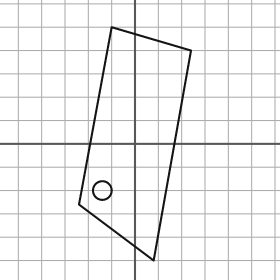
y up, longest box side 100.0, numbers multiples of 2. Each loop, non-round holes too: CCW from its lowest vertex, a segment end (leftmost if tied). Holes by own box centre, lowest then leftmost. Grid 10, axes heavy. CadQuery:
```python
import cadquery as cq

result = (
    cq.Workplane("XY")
    .moveTo(8.0, -50.0)
    .lineTo(24.0, 40.0)
    .lineTo(-10.0, 50.0)
    .lineTo(-24.0, -26.0)
    .close()
    .moveTo(-14.0, -20.0)
    .circle(4.0)
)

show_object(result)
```